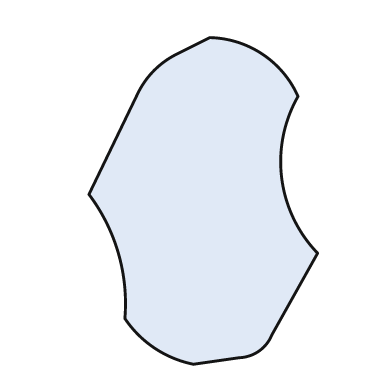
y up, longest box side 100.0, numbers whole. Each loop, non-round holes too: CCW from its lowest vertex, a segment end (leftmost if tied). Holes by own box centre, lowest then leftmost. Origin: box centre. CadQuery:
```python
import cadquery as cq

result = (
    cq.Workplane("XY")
    .moveTo(-3.0, -50.0)
    .lineTo(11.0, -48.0)
    .threePointArc((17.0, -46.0), (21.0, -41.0))
    .lineTo(35.0, -16.0)
    .threePointArc((24.0, 7.0), (29.0, 32.0))
    .threePointArc((18.0, 45.0), (2.0, 50.0))
    .lineTo(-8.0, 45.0)
    .threePointArc((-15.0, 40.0), (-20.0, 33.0))
    .lineTo(-35.0, 2.0)
    .threePointArc((-26.0, -16.0), (-24.0, -36.0))
    .threePointArc((-15.0, -45.0), (-3.0, -50.0))
    .close()
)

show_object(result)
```